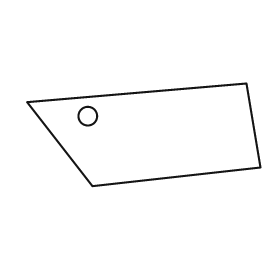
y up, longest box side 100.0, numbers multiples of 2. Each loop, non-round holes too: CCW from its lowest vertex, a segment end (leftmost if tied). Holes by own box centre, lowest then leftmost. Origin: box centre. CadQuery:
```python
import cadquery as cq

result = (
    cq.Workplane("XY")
    .moveTo(-22.0, -22.0)
    .lineTo(50.0, -14.0)
    .lineTo(44.0, 22.0)
    .lineTo(-50.0, 14.0)
    .close()
    .moveTo(-24.0, 8.0)
    .circle(4.0)
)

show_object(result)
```